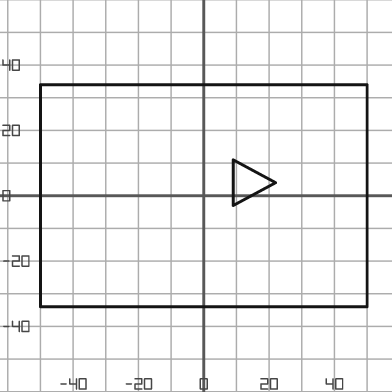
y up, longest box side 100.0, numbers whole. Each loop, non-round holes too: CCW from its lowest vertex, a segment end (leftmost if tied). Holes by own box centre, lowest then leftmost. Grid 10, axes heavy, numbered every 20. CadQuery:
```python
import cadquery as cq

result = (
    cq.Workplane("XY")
    .moveTo(-50.0, -34.0)
    .lineTo(50.0, -34.0)
    .lineTo(50.0, 34.0)
    .lineTo(-50.0, 34.0)
    .close()
    .moveTo(9.0, -3.0)
    .lineTo(22.0, 4.0)
    .lineTo(9.0, 11.0)
    .close()
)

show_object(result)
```